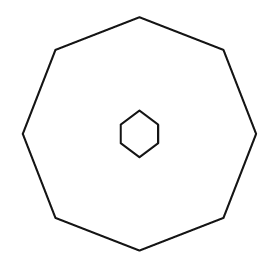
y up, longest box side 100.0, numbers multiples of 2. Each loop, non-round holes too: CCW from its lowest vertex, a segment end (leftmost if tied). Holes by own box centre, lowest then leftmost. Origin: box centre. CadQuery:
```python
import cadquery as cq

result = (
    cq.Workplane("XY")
    .moveTo(0.0, -50.0)
    .lineTo(36.0, -36.0)
    .lineTo(50.0, 0.0)
    .lineTo(36.0, 36.0)
    .lineTo(0.0, 50.0)
    .lineTo(-36.0, 36.0)
    .lineTo(-50.0, 0.0)
    .lineTo(-36.0, -36.0)
    .close()
    .moveTo(0.0, -10.0)
    .lineTo(8.0, -4.0)
    .lineTo(8.0, 4.0)
    .lineTo(0.0, 10.0)
    .lineTo(-8.0, 4.0)
    .lineTo(-8.0, -4.0)
    .close()
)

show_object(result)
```